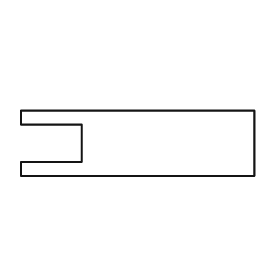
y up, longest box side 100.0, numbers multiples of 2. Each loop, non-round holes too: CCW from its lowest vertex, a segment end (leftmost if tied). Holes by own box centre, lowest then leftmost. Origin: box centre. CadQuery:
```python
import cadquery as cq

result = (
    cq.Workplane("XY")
    .moveTo(-50.0, -14.0)
    .lineTo(50.0, -14.0)
    .lineTo(50.0, 14.0)
    .lineTo(-50.0, 14.0)
    .lineTo(-50.0, 8.0)
    .lineTo(-24.0, 8.0)
    .lineTo(-24.0, -8.0)
    .lineTo(-50.0, -8.0)
    .close()
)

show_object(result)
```